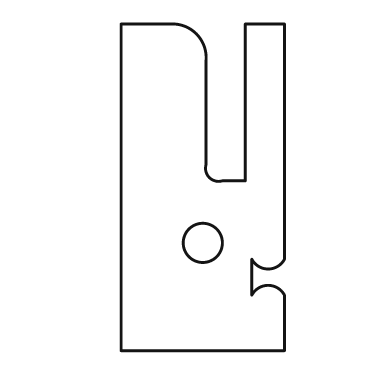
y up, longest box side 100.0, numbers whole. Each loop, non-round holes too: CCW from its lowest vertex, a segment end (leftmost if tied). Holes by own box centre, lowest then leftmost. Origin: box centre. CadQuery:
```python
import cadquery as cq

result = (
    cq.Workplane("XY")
    .moveTo(-25.0, -50.0)
    .lineTo(25.0, -50.0)
    .lineTo(25.0, -33.0)
    .threePointArc((20.0, -30.0), (15.0, -33.0))
    .lineTo(15.0, -22.0)
    .threePointArc((20.0, -25.0), (25.0, -22.0))
    .lineTo(25.0, 50.0)
    .lineTo(13.0, 50.0)
    .lineTo(13.0, 2.0)
    .lineTo(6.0, 2.0)
    .threePointArc((2.0, 3.0), (1.0, 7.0))
    .lineTo(1.0, 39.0)
    .threePointArc((-2.0, 47.0), (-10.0, 50.0))
    .lineTo(-25.0, 50.0)
    .close()
    .moveTo(0.0, -17.0)
    .circle(6.0)
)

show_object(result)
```